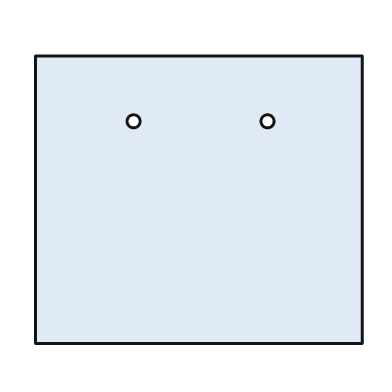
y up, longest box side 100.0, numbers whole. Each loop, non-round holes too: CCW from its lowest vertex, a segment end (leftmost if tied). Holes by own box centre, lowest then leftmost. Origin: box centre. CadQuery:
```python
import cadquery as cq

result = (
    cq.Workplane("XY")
    .moveTo(-50.0, -44.0)
    .lineTo(50.0, -44.0)
    .lineTo(50.0, 44.0)
    .lineTo(-50.0, 44.0)
    .close()
    .moveTo(-20.0, 24.0)
    .circle(2.0)
    .moveTo(21.0, 24.0)
    .circle(2.0)
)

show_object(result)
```